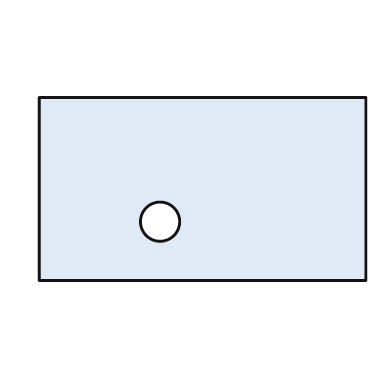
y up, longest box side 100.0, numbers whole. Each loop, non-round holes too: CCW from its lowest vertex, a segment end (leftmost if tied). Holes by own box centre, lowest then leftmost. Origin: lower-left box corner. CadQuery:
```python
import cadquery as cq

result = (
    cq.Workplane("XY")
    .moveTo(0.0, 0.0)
    .lineTo(100.0, 0.0)
    .lineTo(100.0, 56.0)
    .lineTo(0.0, 56.0)
    .close()
    .moveTo(37.0, 18.0)
    .circle(6.0)
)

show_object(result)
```